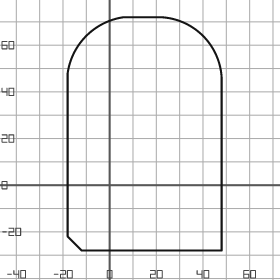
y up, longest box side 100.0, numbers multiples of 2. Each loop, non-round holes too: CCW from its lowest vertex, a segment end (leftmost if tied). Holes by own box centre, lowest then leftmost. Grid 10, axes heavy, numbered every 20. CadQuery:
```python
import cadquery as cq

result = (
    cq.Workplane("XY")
    .moveTo(-12.0, -28.0)
    .lineTo(48.0, -28.0)
    .lineTo(48.0, 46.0)
    .threePointArc((40.0, 64.0), (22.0, 72.0))
    .lineTo(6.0, 72.0)
    .threePointArc((-10.0, 64.0), (-18.0, 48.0))
    .lineTo(-18.0, -22.0)
    .close()
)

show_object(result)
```